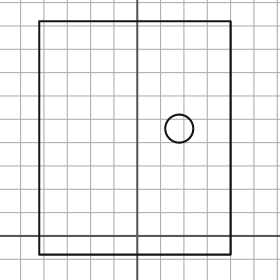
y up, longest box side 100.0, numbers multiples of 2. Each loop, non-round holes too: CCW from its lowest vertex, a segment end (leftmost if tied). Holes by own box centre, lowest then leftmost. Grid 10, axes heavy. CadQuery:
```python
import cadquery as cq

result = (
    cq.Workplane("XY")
    .moveTo(-42.0, -8.0)
    .lineTo(40.0, -8.0)
    .lineTo(40.0, 92.0)
    .lineTo(-42.0, 92.0)
    .close()
    .moveTo(18.0, 46.0)
    .circle(6.0)
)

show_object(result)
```